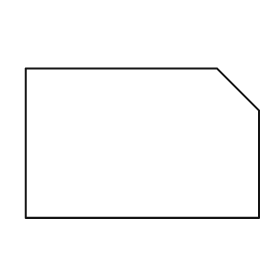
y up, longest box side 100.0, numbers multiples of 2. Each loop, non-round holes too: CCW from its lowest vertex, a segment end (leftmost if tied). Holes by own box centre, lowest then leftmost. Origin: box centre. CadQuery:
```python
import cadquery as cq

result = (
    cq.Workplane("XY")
    .moveTo(-50.0, -32.0)
    .lineTo(50.0, -32.0)
    .lineTo(50.0, 14.0)
    .lineTo(32.0, 32.0)
    .lineTo(-50.0, 32.0)
    .close()
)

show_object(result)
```